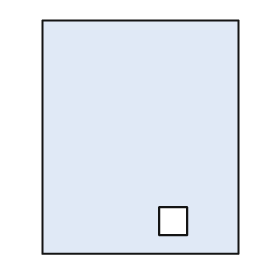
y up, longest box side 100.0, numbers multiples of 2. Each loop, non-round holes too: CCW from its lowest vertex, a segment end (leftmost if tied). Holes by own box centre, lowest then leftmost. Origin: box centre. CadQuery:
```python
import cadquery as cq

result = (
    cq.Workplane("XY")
    .moveTo(-42.0, -50.0)
    .lineTo(42.0, -50.0)
    .lineTo(42.0, 50.0)
    .lineTo(-42.0, 50.0)
    .close()
    .moveTo(8.0, -42.0)
    .lineTo(20.0, -42.0)
    .lineTo(20.0, -30.0)
    .lineTo(8.0, -30.0)
    .close()
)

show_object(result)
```